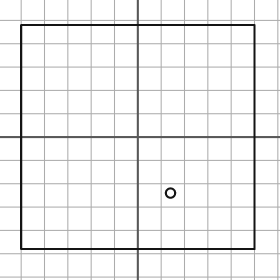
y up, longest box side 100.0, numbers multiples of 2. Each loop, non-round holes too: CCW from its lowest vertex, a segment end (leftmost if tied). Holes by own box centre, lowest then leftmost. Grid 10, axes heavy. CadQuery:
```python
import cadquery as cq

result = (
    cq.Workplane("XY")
    .moveTo(-50.0, -48.0)
    .lineTo(50.0, -48.0)
    .lineTo(50.0, 48.0)
    .lineTo(-50.0, 48.0)
    .close()
    .moveTo(14.0, -24.0)
    .circle(2.0)
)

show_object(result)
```